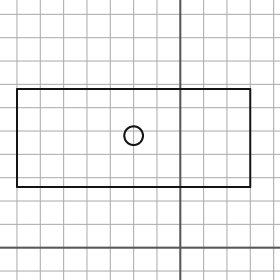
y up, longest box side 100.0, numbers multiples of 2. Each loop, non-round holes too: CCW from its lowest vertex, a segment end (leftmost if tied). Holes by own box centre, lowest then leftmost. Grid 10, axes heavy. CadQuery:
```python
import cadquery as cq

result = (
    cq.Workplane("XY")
    .moveTo(-70.0, 26.0)
    .lineTo(30.0, 26.0)
    .lineTo(30.0, 68.0)
    .lineTo(-70.0, 68.0)
    .close()
    .moveTo(-20.0, 48.0)
    .circle(4.0)
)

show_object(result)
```